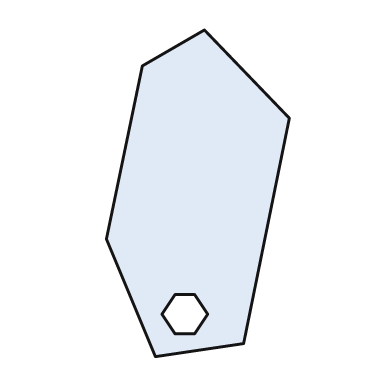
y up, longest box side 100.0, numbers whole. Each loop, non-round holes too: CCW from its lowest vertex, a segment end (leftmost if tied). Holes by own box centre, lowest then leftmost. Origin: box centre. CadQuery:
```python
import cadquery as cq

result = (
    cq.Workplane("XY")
    .moveTo(-13.0, -50.0)
    .lineTo(14.0, -46.0)
    .lineTo(28.0, 23.0)
    .lineTo(2.0, 50.0)
    .lineTo(-17.0, 39.0)
    .lineTo(-28.0, -14.0)
    .close()
    .moveTo(-7.0, -43.0)
    .lineTo(-1.0, -43.0)
    .lineTo(3.0, -37.0)
    .lineTo(-1.0, -31.0)
    .lineTo(-7.0, -31.0)
    .lineTo(-11.0, -37.0)
    .close()
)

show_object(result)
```